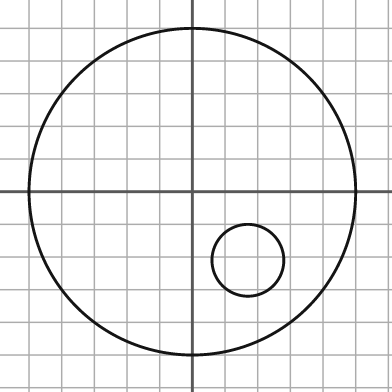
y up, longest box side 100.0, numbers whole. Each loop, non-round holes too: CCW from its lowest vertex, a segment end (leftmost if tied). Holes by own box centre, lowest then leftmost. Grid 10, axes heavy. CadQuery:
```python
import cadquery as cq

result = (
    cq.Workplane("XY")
    .moveTo(0.0, 0.0)
    .circle(50.0)
    .moveTo(17.0, -21.0)
    .circle(11.0)
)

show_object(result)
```